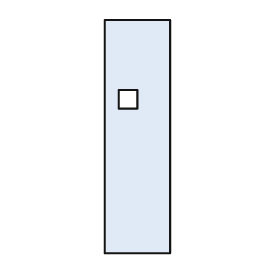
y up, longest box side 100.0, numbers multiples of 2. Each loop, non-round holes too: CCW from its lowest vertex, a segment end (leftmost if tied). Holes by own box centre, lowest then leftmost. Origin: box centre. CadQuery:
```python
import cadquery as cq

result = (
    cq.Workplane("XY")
    .moveTo(-14.0, -50.0)
    .lineTo(14.0, -50.0)
    .lineTo(14.0, 50.0)
    .lineTo(-14.0, 50.0)
    .close()
    .moveTo(-8.0, 12.0)
    .lineTo(0.0, 12.0)
    .lineTo(0.0, 20.0)
    .lineTo(-8.0, 20.0)
    .close()
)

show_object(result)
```